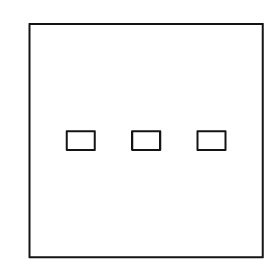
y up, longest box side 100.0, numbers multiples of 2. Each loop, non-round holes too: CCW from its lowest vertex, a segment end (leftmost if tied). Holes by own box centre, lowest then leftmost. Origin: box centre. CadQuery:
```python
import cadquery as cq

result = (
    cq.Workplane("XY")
    .moveTo(-50.0, -50.0)
    .lineTo(50.0, -50.0)
    .lineTo(50.0, 50.0)
    .lineTo(-50.0, 50.0)
    .close()
    .moveTo(-34.0, -4.0)
    .lineTo(-22.0, -4.0)
    .lineTo(-22.0, 4.0)
    .lineTo(-34.0, 4.0)
    .close()
    .moveTo(-6.0, -4.0)
    .lineTo(6.0, -4.0)
    .lineTo(6.0, 4.0)
    .lineTo(-6.0, 4.0)
    .close()
    .moveTo(22.0, -4.0)
    .lineTo(34.0, -4.0)
    .lineTo(34.0, 4.0)
    .lineTo(22.0, 4.0)
    .close()
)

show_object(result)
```